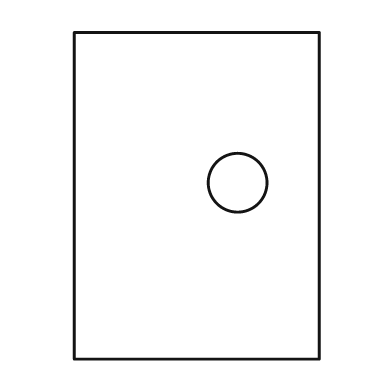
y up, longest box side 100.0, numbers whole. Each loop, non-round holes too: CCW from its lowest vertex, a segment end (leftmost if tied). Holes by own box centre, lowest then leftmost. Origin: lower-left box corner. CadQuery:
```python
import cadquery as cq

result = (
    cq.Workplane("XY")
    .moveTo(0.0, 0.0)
    .lineTo(75.0, 0.0)
    .lineTo(75.0, 100.0)
    .lineTo(0.0, 100.0)
    .close()
    .moveTo(50.0, 54.0)
    .circle(9.0)
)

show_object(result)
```